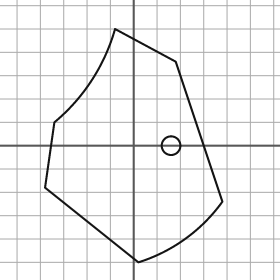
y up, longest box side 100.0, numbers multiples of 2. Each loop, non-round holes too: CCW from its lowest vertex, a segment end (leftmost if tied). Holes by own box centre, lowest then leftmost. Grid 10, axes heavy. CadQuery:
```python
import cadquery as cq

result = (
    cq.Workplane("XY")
    .moveTo(2.0, -50.0)
    .threePointArc((22.0, -40.0), (38.0, -24.0))
    .lineTo(18.0, 36.0)
    .lineTo(-8.0, 50.0)
    .threePointArc((-18.0, 28.0), (-34.0, 10.0))
    .lineTo(-38.0, -18.0)
    .close()
    .moveTo(16.0, 0.0)
    .circle(4.0)
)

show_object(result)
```